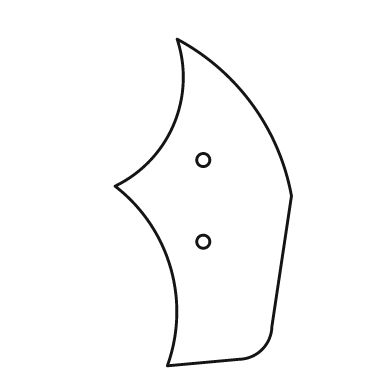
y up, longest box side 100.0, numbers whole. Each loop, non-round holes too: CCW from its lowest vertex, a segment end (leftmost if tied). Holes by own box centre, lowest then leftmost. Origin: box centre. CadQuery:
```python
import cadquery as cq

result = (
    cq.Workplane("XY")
    .moveTo(-11.0, -50.0)
    .lineTo(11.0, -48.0)
    .threePointArc((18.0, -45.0), (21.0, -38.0))
    .lineTo(27.0, 2.0)
    .threePointArc((15.0, 30.0), (-8.0, 50.0))
    .threePointArc((-9.0, 24.0), (-27.0, 5.0))
    .threePointArc((-10.0, -20.0), (-11.0, -50.0))
    .close()
    .moveTo(0.0, -12.0)
    .circle(2.0)
    .moveTo(0.0, 13.0)
    .circle(2.0)
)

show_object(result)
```